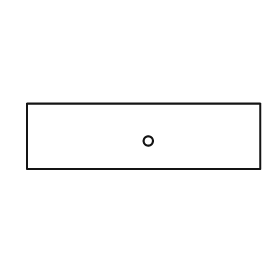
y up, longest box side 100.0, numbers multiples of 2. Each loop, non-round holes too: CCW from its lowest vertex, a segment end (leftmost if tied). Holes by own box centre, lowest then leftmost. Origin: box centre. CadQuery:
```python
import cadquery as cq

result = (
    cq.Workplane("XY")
    .moveTo(-50.0, -14.0)
    .lineTo(50.0, -14.0)
    .lineTo(50.0, 14.0)
    .lineTo(-50.0, 14.0)
    .close()
    .moveTo(2.0, -2.0)
    .circle(2.0)
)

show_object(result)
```